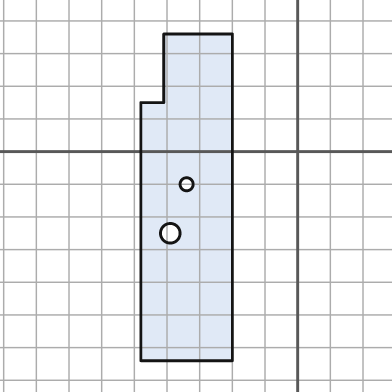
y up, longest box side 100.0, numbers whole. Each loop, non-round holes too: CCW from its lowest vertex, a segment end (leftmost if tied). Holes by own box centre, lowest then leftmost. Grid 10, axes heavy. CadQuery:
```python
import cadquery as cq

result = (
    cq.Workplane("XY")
    .moveTo(-48.0, -64.0)
    .lineTo(-20.0, -64.0)
    .lineTo(-20.0, 36.0)
    .lineTo(-41.0, 36.0)
    .lineTo(-41.0, 15.0)
    .lineTo(-48.0, 15.0)
    .close()
    .moveTo(-39.0, -25.0)
    .circle(3.0)
    .moveTo(-34.0, -10.0)
    .circle(2.0)
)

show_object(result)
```